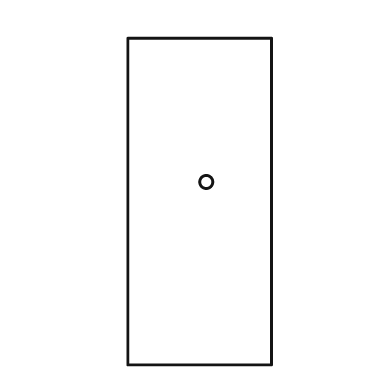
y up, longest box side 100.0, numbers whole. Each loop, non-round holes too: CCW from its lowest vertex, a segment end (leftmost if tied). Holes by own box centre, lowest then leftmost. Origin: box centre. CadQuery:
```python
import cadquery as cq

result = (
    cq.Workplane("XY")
    .moveTo(-22.0, -50.0)
    .lineTo(22.0, -50.0)
    .lineTo(22.0, 50.0)
    .lineTo(-22.0, 50.0)
    .close()
    .moveTo(2.0, 6.0)
    .circle(2.0)
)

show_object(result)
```